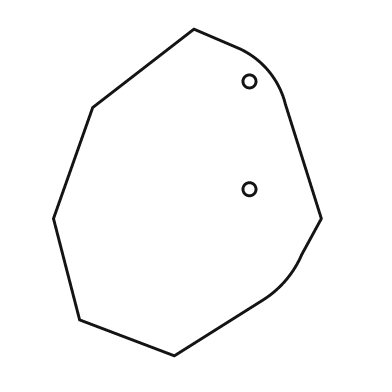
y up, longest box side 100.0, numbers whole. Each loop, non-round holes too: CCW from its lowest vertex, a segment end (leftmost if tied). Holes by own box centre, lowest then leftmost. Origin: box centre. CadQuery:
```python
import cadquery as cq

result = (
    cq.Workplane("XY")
    .moveTo(-4.0, -50.0)
    .lineTo(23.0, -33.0)
    .threePointArc((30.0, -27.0), (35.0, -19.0))
    .lineTo(41.0, -8.0)
    .lineTo(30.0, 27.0)
    .threePointArc((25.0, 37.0), (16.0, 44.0))
    .lineTo(2.0, 50.0)
    .lineTo(-29.0, 26.0)
    .lineTo(-41.0, -8.0)
    .lineTo(-33.0, -39.0)
    .close()
    .moveTo(19.0, 1.0)
    .circle(2.0)
    .moveTo(19.0, 34.0)
    .circle(2.0)
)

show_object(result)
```